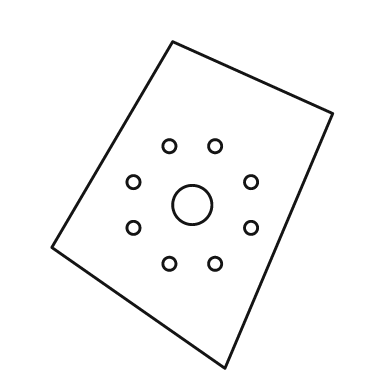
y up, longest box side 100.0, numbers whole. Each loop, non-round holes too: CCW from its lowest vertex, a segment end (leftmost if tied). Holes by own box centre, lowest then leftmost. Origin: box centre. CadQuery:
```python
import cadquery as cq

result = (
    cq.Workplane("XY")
    .moveTo(10.0, -50.0)
    .lineTo(43.0, 28.0)
    .lineTo(-6.0, 50.0)
    .lineTo(-43.0, -13.0)
    .close()
    .moveTo(-7.0, -18.0)
    .circle(2.0)
    .moveTo(7.0, -18.0)
    .circle(2.0)
    .moveTo(-18.0, -7.0)
    .circle(2.0)
    .moveTo(18.0, -7.0)
    .circle(2.0)
    .moveTo(0.0, 0.0)
    .circle(6.0)
    .moveTo(-18.0, 7.0)
    .circle(2.0)
    .moveTo(18.0, 7.0)
    .circle(2.0)
    .moveTo(-7.0, 18.0)
    .circle(2.0)
    .moveTo(7.0, 18.0)
    .circle(2.0)
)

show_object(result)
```